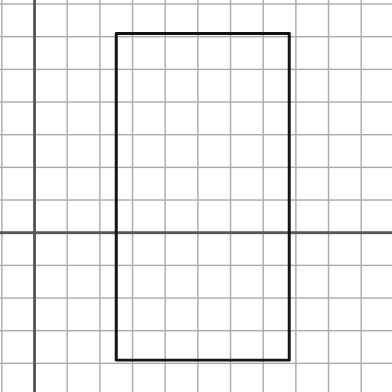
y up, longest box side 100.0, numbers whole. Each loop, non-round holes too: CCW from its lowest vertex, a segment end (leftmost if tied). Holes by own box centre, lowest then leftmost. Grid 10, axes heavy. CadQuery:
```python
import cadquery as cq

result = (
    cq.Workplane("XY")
    .moveTo(25.0, -39.0)
    .lineTo(78.0, -39.0)
    .lineTo(78.0, 61.0)
    .lineTo(25.0, 61.0)
    .close()
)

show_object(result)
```